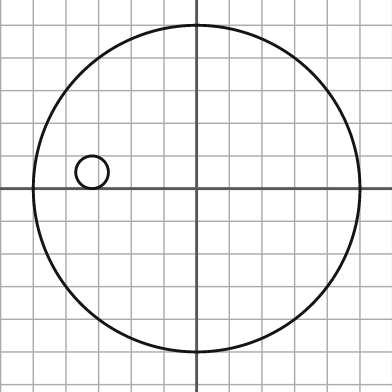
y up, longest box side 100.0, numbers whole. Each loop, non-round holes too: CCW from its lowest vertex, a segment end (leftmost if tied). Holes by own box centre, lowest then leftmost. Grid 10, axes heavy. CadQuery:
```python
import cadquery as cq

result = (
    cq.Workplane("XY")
    .moveTo(0.0, 0.0)
    .circle(50.0)
    .moveTo(-32.0, 5.0)
    .circle(5.0)
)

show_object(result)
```